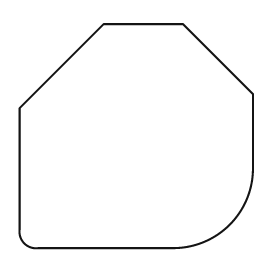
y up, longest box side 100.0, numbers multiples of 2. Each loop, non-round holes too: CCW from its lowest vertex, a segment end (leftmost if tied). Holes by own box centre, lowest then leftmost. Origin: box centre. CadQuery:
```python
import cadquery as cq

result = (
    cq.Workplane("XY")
    .moveTo(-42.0, -48.0)
    .lineTo(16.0, -48.0)
    .threePointArc((40.0, -38.0), (50.0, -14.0))
    .lineTo(50.0, 18.0)
    .lineTo(20.0, 48.0)
    .lineTo(-14.0, 48.0)
    .lineTo(-50.0, 12.0)
    .lineTo(-50.0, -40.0)
    .threePointArc((-48.0, -46.0), (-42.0, -48.0))
    .close()
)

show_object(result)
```